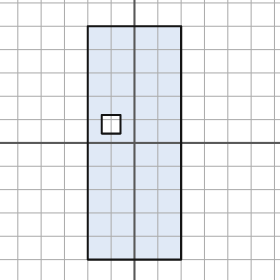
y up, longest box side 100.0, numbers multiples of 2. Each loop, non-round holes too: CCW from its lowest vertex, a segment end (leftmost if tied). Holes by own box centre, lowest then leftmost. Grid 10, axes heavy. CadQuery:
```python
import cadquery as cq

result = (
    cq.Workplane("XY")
    .moveTo(-20.0, -50.0)
    .lineTo(20.0, -50.0)
    .lineTo(20.0, 50.0)
    .lineTo(-20.0, 50.0)
    .close()
    .moveTo(-14.0, 4.0)
    .lineTo(-6.0, 4.0)
    .lineTo(-6.0, 12.0)
    .lineTo(-14.0, 12.0)
    .close()
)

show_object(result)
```